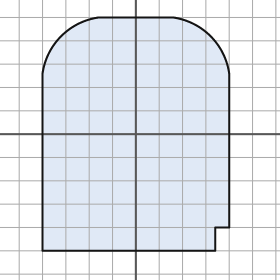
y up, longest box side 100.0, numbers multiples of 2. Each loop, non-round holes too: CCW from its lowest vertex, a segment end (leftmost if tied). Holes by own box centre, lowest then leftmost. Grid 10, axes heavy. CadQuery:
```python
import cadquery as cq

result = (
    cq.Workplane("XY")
    .moveTo(-40.0, -50.0)
    .lineTo(34.0, -50.0)
    .lineTo(34.0, -40.0)
    .lineTo(40.0, -40.0)
    .lineTo(40.0, 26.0)
    .threePointArc((32.0, 42.0), (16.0, 50.0))
    .lineTo(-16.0, 50.0)
    .threePointArc((-32.0, 42.0), (-40.0, 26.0))
    .close()
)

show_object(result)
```